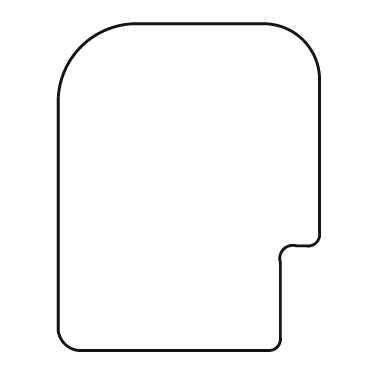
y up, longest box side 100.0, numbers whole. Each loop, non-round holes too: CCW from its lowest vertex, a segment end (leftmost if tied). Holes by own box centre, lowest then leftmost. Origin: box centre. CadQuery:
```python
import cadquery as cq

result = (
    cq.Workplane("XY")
    .moveTo(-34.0, -50.0)
    .lineTo(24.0, -50.0)
    .threePointArc((27.0, -49.0), (28.0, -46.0))
    .lineTo(28.0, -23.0)
    .threePointArc((29.0, -19.0), (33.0, -18.0))
    .lineTo(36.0, -18.0)
    .threePointArc((39.0, -17.0), (40.0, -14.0))
    .lineTo(40.0, 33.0)
    .threePointArc((35.0, 45.0), (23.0, 50.0))
    .lineTo(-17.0, 50.0)
    .threePointArc((-33.0, 43.0), (-40.0, 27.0))
    .lineTo(-40.0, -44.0)
    .threePointArc((-38.0, -48.0), (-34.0, -50.0))
    .close()
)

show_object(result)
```